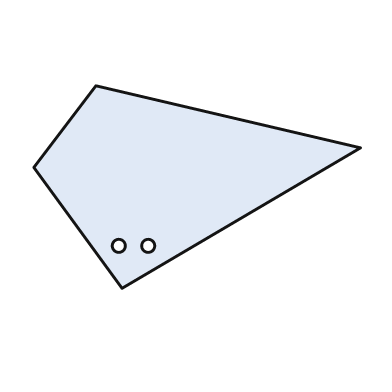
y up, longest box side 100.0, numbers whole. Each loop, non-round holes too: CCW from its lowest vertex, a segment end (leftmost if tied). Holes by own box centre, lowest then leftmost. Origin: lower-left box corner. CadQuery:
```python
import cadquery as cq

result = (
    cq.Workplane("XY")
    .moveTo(27.0, 0.0)
    .lineTo(100.0, 43.0)
    .lineTo(19.0, 62.0)
    .lineTo(0.0, 37.0)
    .close()
    .moveTo(26.0, 13.0)
    .circle(2.0)
    .moveTo(35.0, 13.0)
    .circle(2.0)
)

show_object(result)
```